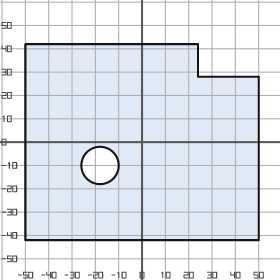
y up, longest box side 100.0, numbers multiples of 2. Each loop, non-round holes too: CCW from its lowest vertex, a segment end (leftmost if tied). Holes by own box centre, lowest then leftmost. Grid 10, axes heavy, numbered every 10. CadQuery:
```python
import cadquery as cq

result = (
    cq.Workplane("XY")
    .moveTo(-50.0, -42.0)
    .lineTo(50.0, -42.0)
    .lineTo(50.0, 28.0)
    .lineTo(24.0, 28.0)
    .lineTo(24.0, 42.0)
    .lineTo(-50.0, 42.0)
    .close()
    .moveTo(-18.0, -10.0)
    .circle(8.0)
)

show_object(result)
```